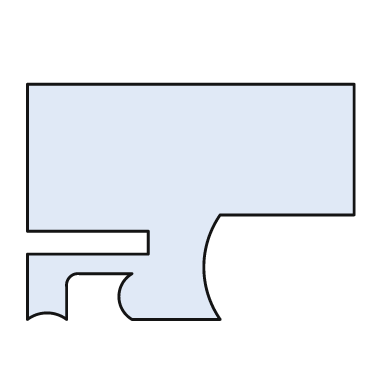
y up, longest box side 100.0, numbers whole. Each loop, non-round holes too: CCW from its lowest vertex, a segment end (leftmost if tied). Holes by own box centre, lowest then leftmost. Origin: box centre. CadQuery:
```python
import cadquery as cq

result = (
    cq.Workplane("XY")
    .moveTo(-50.0, -36.0)
    .threePointArc((-44.0, -34.0), (-38.0, -36.0))
    .lineTo(-38.0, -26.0)
    .threePointArc((-37.0, -23.0), (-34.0, -22.0))
    .lineTo(-18.0, -22.0)
    .threePointArc((-22.0, -29.0), (-18.0, -36.0))
    .lineTo(9.0, -36.0)
    .threePointArc((4.0, -20.0), (9.0, -4.0))
    .lineTo(50.0, -4.0)
    .lineTo(50.0, 36.0)
    .lineTo(-50.0, 36.0)
    .lineTo(-50.0, -9.0)
    .lineTo(-13.0, -9.0)
    .lineTo(-13.0, -16.0)
    .lineTo(-50.0, -16.0)
    .close()
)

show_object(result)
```